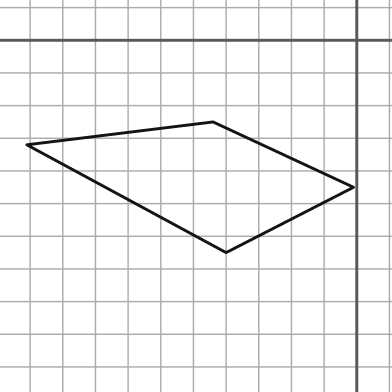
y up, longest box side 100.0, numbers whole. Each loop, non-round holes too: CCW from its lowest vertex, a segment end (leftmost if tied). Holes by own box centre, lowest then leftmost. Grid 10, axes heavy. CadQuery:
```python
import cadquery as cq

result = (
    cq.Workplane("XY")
    .moveTo(-40.0, -65.0)
    .lineTo(-1.0, -45.0)
    .lineTo(-44.0, -25.0)
    .lineTo(-101.0, -32.0)
    .close()
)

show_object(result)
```